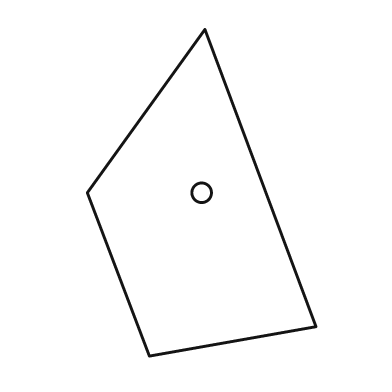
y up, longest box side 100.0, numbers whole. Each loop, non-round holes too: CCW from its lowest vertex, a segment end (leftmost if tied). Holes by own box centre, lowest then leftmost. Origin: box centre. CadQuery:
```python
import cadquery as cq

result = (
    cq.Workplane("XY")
    .moveTo(-16.0, -50.0)
    .lineTo(35.0, -41.0)
    .lineTo(1.0, 50.0)
    .lineTo(-35.0, 0.0)
    .close()
    .moveTo(0.0, 0.0)
    .circle(3.0)
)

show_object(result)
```